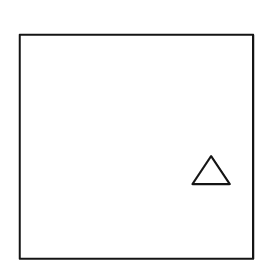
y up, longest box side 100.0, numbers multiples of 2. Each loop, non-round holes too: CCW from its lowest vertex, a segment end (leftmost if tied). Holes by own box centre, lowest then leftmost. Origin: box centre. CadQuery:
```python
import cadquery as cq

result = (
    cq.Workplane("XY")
    .moveTo(-50.0, -48.0)
    .lineTo(50.0, -48.0)
    .lineTo(50.0, 48.0)
    .lineTo(-50.0, 48.0)
    .close()
    .moveTo(24.0, -16.0)
    .lineTo(40.0, -16.0)
    .lineTo(32.0, -4.0)
    .close()
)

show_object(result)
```